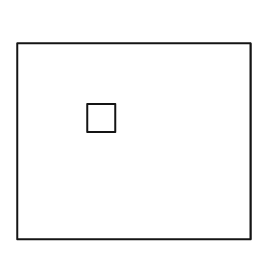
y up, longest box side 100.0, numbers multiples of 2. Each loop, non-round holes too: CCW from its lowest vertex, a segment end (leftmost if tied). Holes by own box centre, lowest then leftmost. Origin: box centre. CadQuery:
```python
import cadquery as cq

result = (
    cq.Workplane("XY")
    .moveTo(-50.0, -42.0)
    .lineTo(50.0, -42.0)
    .lineTo(50.0, 42.0)
    .lineTo(-50.0, 42.0)
    .close()
    .moveTo(-20.0, 4.0)
    .lineTo(-8.0, 4.0)
    .lineTo(-8.0, 16.0)
    .lineTo(-20.0, 16.0)
    .close()
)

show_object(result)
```